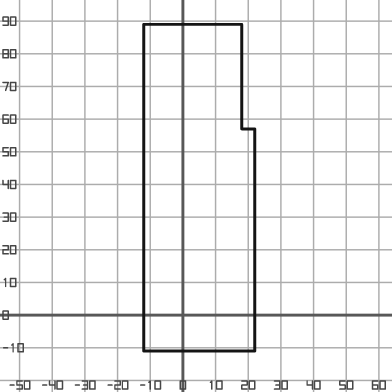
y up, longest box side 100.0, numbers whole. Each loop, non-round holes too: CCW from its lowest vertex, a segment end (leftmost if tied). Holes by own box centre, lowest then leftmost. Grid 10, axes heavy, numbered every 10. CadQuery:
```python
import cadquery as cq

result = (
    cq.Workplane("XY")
    .moveTo(-12.0, -11.0)
    .lineTo(22.0, -11.0)
    .lineTo(22.0, 57.0)
    .lineTo(18.0, 57.0)
    .lineTo(18.0, 89.0)
    .lineTo(-12.0, 89.0)
    .close()
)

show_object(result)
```